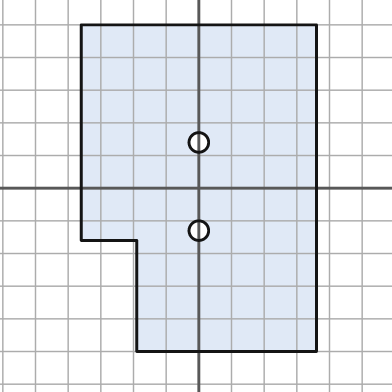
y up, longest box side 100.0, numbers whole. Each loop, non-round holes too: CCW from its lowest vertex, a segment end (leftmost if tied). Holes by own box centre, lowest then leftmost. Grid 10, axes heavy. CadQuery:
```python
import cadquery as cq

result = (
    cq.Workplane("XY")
    .moveTo(-19.0, -50.0)
    .lineTo(36.0, -50.0)
    .lineTo(36.0, 50.0)
    .lineTo(-36.0, 50.0)
    .lineTo(-36.0, -16.0)
    .lineTo(-19.0, -16.0)
    .close()
    .moveTo(0.0, -13.0)
    .circle(3.0)
    .moveTo(0.0, 14.0)
    .circle(3.0)
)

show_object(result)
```